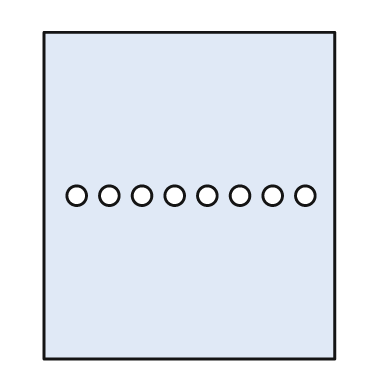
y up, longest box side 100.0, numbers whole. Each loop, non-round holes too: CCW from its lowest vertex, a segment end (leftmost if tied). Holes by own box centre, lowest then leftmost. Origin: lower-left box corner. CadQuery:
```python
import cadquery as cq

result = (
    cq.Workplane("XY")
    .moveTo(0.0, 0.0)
    .lineTo(89.0, 0.0)
    .lineTo(89.0, 100.0)
    .lineTo(0.0, 100.0)
    .close()
    .moveTo(10.0, 50.0)
    .circle(3.0)
    .moveTo(20.0, 50.0)
    .circle(3.0)
    .moveTo(30.0, 50.0)
    .circle(3.0)
    .moveTo(40.0, 50.0)
    .circle(3.0)
    .moveTo(50.0, 50.0)
    .circle(3.0)
    .moveTo(60.0, 50.0)
    .circle(3.0)
    .moveTo(70.0, 50.0)
    .circle(3.0)
    .moveTo(80.0, 50.0)
    .circle(3.0)
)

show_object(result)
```